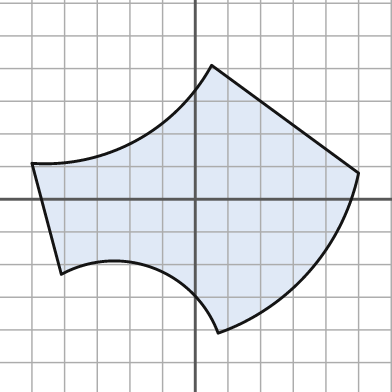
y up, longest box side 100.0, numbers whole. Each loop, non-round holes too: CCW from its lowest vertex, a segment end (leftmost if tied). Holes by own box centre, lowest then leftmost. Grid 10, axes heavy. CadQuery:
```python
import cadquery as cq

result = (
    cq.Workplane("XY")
    .moveTo(7.0, -41.0)
    .threePointArc((35.0, -22.0), (50.0, 8.0))
    .lineTo(5.0, 41.0)
    .threePointArc((-18.0, 18.0), (-50.0, 11.0))
    .lineTo(-41.0, -23.0)
    .threePointArc((-13.0, -21.0), (7.0, -41.0))
    .close()
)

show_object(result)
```